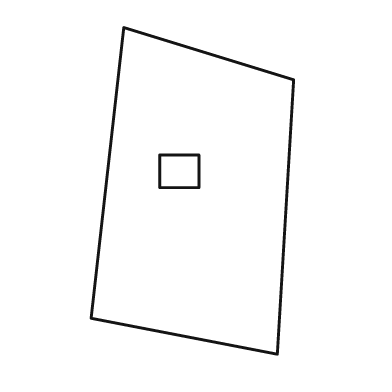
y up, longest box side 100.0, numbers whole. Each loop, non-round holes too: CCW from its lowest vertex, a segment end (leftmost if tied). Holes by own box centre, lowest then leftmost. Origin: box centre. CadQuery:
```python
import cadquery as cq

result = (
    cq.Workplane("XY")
    .moveTo(26.0, -50.0)
    .lineTo(31.0, 34.0)
    .lineTo(-21.0, 50.0)
    .lineTo(-31.0, -39.0)
    .close()
    .moveTo(-10.0, 1.0)
    .lineTo(2.0, 1.0)
    .lineTo(2.0, 11.0)
    .lineTo(-10.0, 11.0)
    .close()
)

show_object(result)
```